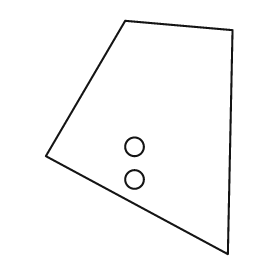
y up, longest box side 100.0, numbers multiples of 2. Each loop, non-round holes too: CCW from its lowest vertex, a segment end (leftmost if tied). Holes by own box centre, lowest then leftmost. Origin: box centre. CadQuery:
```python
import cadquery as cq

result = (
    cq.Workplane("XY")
    .moveTo(38.0, -50.0)
    .lineTo(40.0, 46.0)
    .lineTo(-6.0, 50.0)
    .lineTo(-40.0, -8.0)
    .close()
    .moveTo(-2.0, -18.0)
    .circle(4.0)
    .moveTo(-2.0, -4.0)
    .circle(4.0)
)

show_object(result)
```